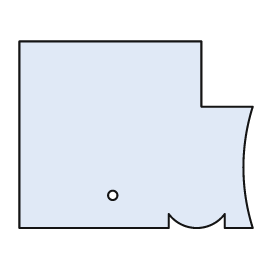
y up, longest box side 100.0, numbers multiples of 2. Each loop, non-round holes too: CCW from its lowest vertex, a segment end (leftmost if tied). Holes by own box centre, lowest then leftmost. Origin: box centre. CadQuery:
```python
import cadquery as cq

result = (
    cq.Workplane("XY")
    .moveTo(-50.0, -40.0)
    .lineTo(14.0, -40.0)
    .lineTo(14.0, -34.0)
    .threePointArc((26.0, -40.0), (38.0, -34.0))
    .lineTo(38.0, -40.0)
    .lineTo(50.0, -40.0)
    .threePointArc((46.0, -14.0), (50.0, 12.0))
    .lineTo(28.0, 12.0)
    .lineTo(28.0, 40.0)
    .lineTo(-50.0, 40.0)
    .close()
    .moveTo(-10.0, -26.0)
    .circle(2.0)
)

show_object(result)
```